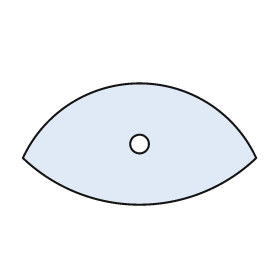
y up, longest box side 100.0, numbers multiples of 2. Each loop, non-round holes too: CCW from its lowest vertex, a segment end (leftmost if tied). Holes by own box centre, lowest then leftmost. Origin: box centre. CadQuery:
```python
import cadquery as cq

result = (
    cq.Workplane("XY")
    .moveTo(-50.0, -6.0)
    .threePointArc((0.0, -26.0), (50.0, -6.0))
    .threePointArc((0.0, 26.0), (-50.0, -6.0))
    .close()
    .moveTo(0.0, 0.0)
    .circle(4.0)
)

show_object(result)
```